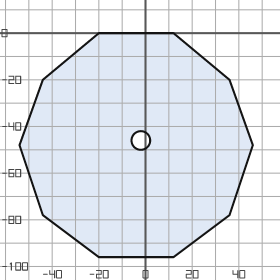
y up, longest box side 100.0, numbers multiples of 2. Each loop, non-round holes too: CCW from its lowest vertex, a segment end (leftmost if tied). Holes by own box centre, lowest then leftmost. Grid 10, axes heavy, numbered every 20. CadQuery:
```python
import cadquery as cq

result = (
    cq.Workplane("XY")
    .moveTo(-20.0, -96.0)
    .lineTo(12.0, -96.0)
    .lineTo(36.0, -78.0)
    .lineTo(46.0, -48.0)
    .lineTo(36.0, -20.0)
    .lineTo(12.0, 0.0)
    .lineTo(-20.0, 0.0)
    .lineTo(-44.0, -20.0)
    .lineTo(-54.0, -48.0)
    .lineTo(-44.0, -78.0)
    .close()
    .moveTo(-2.0, -46.0)
    .circle(4.0)
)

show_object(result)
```